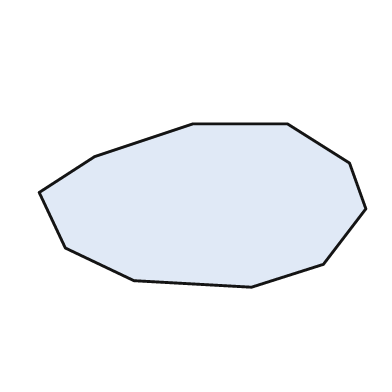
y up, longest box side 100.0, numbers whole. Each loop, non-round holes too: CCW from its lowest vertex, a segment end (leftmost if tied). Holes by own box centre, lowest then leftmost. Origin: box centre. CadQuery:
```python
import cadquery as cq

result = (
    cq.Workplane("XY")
    .moveTo(15.0, -25.0)
    .lineTo(37.0, -18.0)
    .lineTo(50.0, -1.0)
    .lineTo(45.0, 13.0)
    .lineTo(26.0, 25.0)
    .lineTo(-3.0, 25.0)
    .lineTo(-33.0, 15.0)
    .lineTo(-50.0, 4.0)
    .lineTo(-42.0, -13.0)
    .lineTo(-21.0, -23.0)
    .close()
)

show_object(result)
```